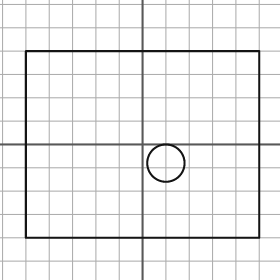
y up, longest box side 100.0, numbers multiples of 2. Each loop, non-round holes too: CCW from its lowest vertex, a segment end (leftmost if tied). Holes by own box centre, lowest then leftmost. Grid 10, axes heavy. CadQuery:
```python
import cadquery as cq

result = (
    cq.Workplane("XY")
    .moveTo(-50.0, -40.0)
    .lineTo(50.0, -40.0)
    .lineTo(50.0, 40.0)
    .lineTo(-50.0, 40.0)
    .close()
    .moveTo(10.0, -8.0)
    .circle(8.0)
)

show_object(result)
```